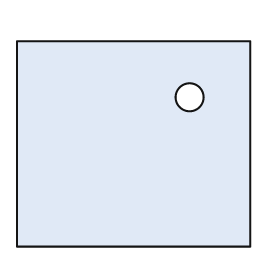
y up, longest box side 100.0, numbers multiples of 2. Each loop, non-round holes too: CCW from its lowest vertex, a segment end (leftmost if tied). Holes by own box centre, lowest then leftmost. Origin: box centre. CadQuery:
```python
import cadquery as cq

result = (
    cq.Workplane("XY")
    .moveTo(-50.0, -44.0)
    .lineTo(50.0, -44.0)
    .lineTo(50.0, 44.0)
    .lineTo(-50.0, 44.0)
    .close()
    .moveTo(24.0, 20.0)
    .circle(6.0)
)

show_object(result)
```